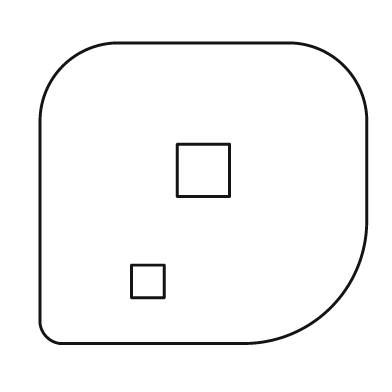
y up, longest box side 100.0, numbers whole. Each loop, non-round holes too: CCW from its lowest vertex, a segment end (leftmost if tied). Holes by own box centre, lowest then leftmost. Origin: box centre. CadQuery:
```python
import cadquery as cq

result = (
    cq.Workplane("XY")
    .moveTo(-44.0, -46.0)
    .lineTo(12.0, -46.0)
    .threePointArc((39.0, -35.0), (50.0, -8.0))
    .lineTo(50.0, 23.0)
    .threePointArc((43.0, 39.0), (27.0, 46.0))
    .lineTo(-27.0, 46.0)
    .threePointArc((-43.0, 39.0), (-50.0, 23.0))
    .lineTo(-50.0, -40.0)
    .threePointArc((-48.0, -44.0), (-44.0, -46.0))
    .close()
    .moveTo(-22.0, -32.0)
    .lineTo(-12.0, -32.0)
    .lineTo(-12.0, -22.0)
    .lineTo(-22.0, -22.0)
    .close()
    .moveTo(-8.0, -1.0)
    .lineTo(8.0, -1.0)
    .lineTo(8.0, 15.0)
    .lineTo(-8.0, 15.0)
    .close()
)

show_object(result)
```